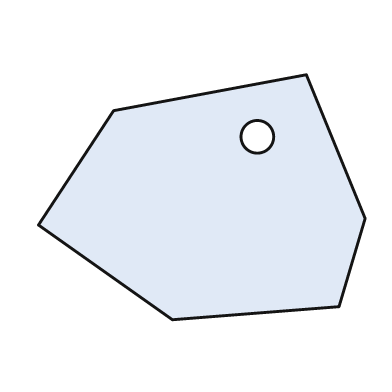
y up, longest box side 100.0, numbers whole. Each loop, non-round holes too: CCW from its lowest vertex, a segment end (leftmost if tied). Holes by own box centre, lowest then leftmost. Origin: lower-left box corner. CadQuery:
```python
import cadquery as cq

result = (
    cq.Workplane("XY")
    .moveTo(41.0, 0.0)
    .lineTo(92.0, 4.0)
    .lineTo(100.0, 31.0)
    .lineTo(82.0, 75.0)
    .lineTo(23.0, 64.0)
    .lineTo(0.0, 29.0)
    .close()
    .moveTo(67.0, 56.0)
    .circle(5.0)
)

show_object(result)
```